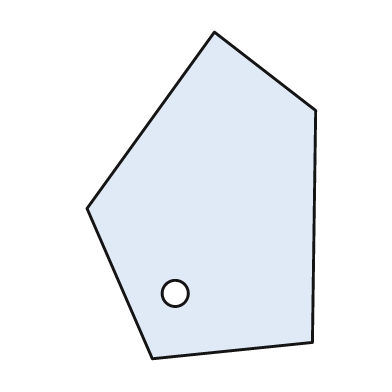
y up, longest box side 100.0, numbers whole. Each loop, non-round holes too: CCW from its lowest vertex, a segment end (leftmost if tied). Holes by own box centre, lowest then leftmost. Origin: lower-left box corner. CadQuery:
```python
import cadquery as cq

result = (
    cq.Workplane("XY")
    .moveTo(20.0, 0.0)
    .lineTo(69.0, 5.0)
    .lineTo(70.0, 76.0)
    .lineTo(39.0, 100.0)
    .lineTo(0.0, 46.0)
    .close()
    .moveTo(27.0, 20.0)
    .circle(4.0)
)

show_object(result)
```